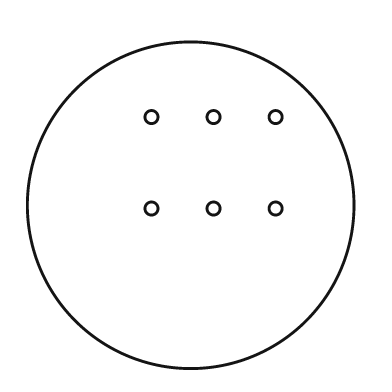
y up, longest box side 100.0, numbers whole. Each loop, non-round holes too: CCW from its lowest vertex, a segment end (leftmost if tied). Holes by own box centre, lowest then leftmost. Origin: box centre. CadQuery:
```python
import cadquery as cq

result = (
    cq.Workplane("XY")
    .moveTo(0.0, 0.0)
    .circle(50.0)
    .moveTo(-12.0, -1.0)
    .circle(2.0)
    .moveTo(7.0, -1.0)
    .circle(2.0)
    .moveTo(26.0, -1.0)
    .circle(2.0)
    .moveTo(-12.0, 27.0)
    .circle(2.0)
    .moveTo(7.0, 27.0)
    .circle(2.0)
    .moveTo(26.0, 27.0)
    .circle(2.0)
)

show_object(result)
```